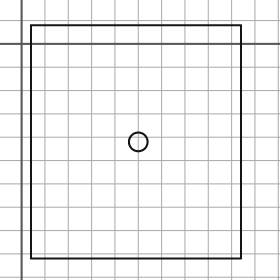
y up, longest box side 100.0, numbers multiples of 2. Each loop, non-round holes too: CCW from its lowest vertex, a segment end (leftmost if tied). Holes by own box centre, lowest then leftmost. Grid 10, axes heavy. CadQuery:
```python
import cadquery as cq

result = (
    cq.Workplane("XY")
    .moveTo(4.0, -92.0)
    .lineTo(94.0, -92.0)
    .lineTo(94.0, 8.0)
    .lineTo(4.0, 8.0)
    .close()
    .moveTo(50.0, -42.0)
    .circle(4.0)
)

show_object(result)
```